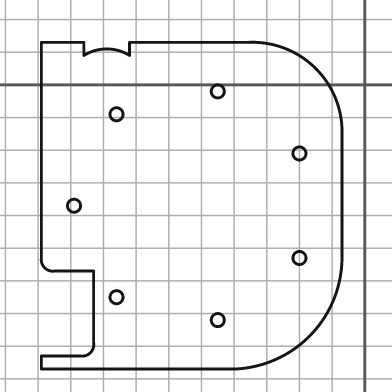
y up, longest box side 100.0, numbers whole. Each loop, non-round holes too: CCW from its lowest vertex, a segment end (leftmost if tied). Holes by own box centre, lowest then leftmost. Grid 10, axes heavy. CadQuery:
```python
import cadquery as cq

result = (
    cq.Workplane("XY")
    .moveTo(-99.0, -87.0)
    .lineTo(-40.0, -87.0)
    .threePointArc((-17.0, -77.0), (-7.0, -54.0))
    .lineTo(-7.0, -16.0)
    .threePointArc((-15.0, 5.0), (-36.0, 13.0))
    .lineTo(-72.0, 13.0)
    .lineTo(-72.0, 9.0)
    .threePointArc((-79.0, 11.0), (-86.0, 9.0))
    .lineTo(-86.0, 13.0)
    .lineTo(-99.0, 13.0)
    .lineTo(-99.0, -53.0)
    .threePointArc((-98.0, -56.0), (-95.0, -57.0))
    .lineTo(-83.0, -57.0)
    .lineTo(-83.0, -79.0)
    .threePointArc((-84.0, -82.0), (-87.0, -83.0))
    .lineTo(-99.0, -83.0)
    .close()
    .moveTo(-45.0, -72.0)
    .circle(2.0)
    .moveTo(-76.0, -65.0)
    .circle(2.0)
    .moveTo(-20.0, -53.0)
    .circle(2.0)
    .moveTo(-89.0, -37.0)
    .circle(2.0)
    .moveTo(-20.0, -21.0)
    .circle(2.0)
    .moveTo(-76.0, -9.0)
    .circle(2.0)
    .moveTo(-45.0, -2.0)
    .circle(2.0)
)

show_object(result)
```